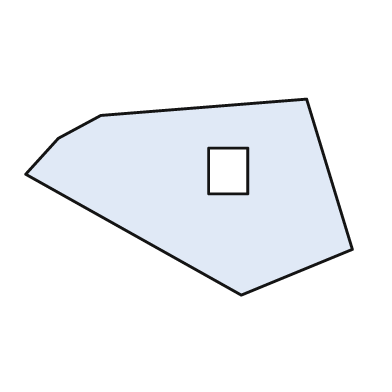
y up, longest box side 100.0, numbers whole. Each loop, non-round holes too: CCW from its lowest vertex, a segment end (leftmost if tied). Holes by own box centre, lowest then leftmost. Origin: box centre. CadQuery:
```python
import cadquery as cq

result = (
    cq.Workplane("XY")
    .moveTo(16.0, -30.0)
    .lineTo(50.0, -16.0)
    .lineTo(36.0, 30.0)
    .lineTo(-27.0, 25.0)
    .lineTo(-40.0, 18.0)
    .lineTo(-50.0, 7.0)
    .close()
    .moveTo(6.0, 1.0)
    .lineTo(18.0, 1.0)
    .lineTo(18.0, 15.0)
    .lineTo(6.0, 15.0)
    .close()
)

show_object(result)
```